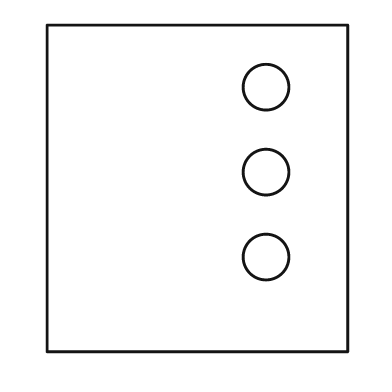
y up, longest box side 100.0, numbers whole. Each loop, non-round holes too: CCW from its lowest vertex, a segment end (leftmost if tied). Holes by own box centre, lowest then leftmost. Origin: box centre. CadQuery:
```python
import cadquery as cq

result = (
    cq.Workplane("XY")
    .moveTo(-46.0, -50.0)
    .lineTo(46.0, -50.0)
    .lineTo(46.0, 50.0)
    .lineTo(-46.0, 50.0)
    .close()
    .moveTo(21.0, -21.0)
    .circle(7.0)
    .moveTo(21.0, 5.0)
    .circle(7.0)
    .moveTo(21.0, 31.0)
    .circle(7.0)
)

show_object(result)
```